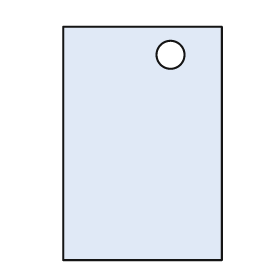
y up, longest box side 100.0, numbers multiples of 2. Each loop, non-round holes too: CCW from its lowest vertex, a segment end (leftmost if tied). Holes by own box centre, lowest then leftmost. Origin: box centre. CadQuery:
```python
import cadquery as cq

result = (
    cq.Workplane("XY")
    .moveTo(-34.0, -50.0)
    .lineTo(34.0, -50.0)
    .lineTo(34.0, 50.0)
    .lineTo(-34.0, 50.0)
    .close()
    .moveTo(12.0, 38.0)
    .circle(6.0)
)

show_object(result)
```